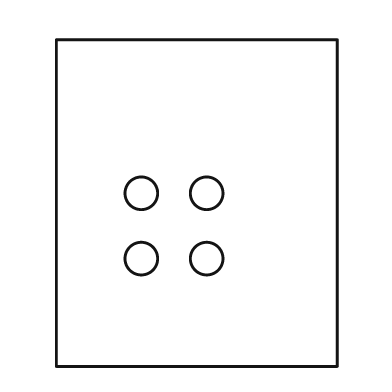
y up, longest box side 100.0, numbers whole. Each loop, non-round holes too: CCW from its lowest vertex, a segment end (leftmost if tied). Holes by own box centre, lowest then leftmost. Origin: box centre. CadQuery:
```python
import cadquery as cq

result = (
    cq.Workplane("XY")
    .moveTo(-43.0, -50.0)
    .lineTo(43.0, -50.0)
    .lineTo(43.0, 50.0)
    .lineTo(-43.0, 50.0)
    .close()
    .moveTo(-17.0, -17.0)
    .circle(5.0)
    .moveTo(3.0, -17.0)
    .circle(5.0)
    .moveTo(-17.0, 3.0)
    .circle(5.0)
    .moveTo(3.0, 3.0)
    .circle(5.0)
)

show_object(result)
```